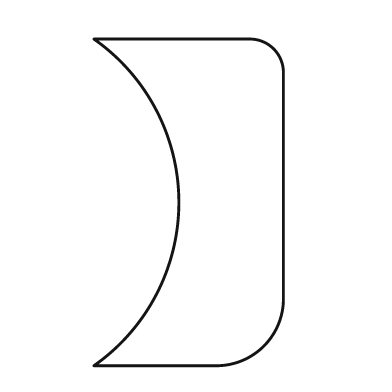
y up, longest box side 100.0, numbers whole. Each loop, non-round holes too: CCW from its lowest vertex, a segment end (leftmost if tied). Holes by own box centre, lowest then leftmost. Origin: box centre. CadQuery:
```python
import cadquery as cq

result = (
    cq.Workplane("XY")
    .moveTo(-29.0, -50.0)
    .lineTo(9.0, -50.0)
    .threePointArc((23.0, -44.0), (29.0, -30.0))
    .lineTo(29.0, 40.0)
    .threePointArc((26.0, 47.0), (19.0, 50.0))
    .lineTo(-29.0, 50.0)
    .threePointArc((-3.0, 0.0), (-29.0, -50.0))
    .close()
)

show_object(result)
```